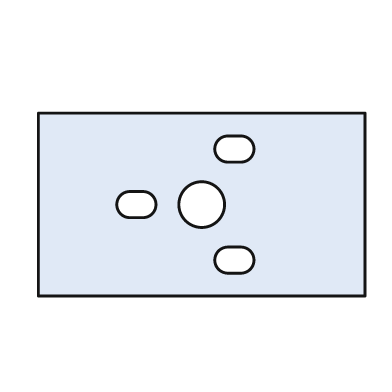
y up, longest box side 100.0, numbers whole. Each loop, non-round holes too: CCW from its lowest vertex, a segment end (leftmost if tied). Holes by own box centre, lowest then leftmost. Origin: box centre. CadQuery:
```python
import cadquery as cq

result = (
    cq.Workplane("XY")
    .moveTo(-50.0, -28.0)
    .lineTo(50.0, -28.0)
    .lineTo(50.0, 28.0)
    .lineTo(-50.0, 28.0)
    .close()
    .moveTo(8.0, -21.0)
    .lineTo(12.0, -21.0)
    .threePointArc((16.0, -17.0), (12.0, -13.0))
    .lineTo(8.0, -13.0)
    .threePointArc((4.0, -17.0), (8.0, -21.0))
    .close()
    .moveTo(-22.0, -4.0)
    .lineTo(-18.0, -4.0)
    .threePointArc((-14.0, 0.0), (-18.0, 4.0))
    .lineTo(-22.0, 4.0)
    .threePointArc((-26.0, 0.0), (-22.0, -4.0))
    .close()
    .moveTo(0.0, 0.0)
    .circle(7.0)
    .moveTo(8.0, 13.0)
    .lineTo(12.0, 13.0)
    .threePointArc((16.0, 17.0), (12.0, 21.0))
    .lineTo(8.0, 21.0)
    .threePointArc((4.0, 17.0), (8.0, 13.0))
    .close()
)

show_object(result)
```